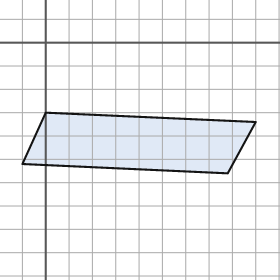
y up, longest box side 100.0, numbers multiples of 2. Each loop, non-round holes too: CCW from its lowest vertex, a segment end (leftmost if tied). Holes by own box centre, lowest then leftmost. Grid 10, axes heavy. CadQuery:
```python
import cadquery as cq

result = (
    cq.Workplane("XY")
    .moveTo(78.0, -56.0)
    .lineTo(90.0, -34.0)
    .lineTo(0.0, -30.0)
    .lineTo(-10.0, -52.0)
    .close()
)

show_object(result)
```